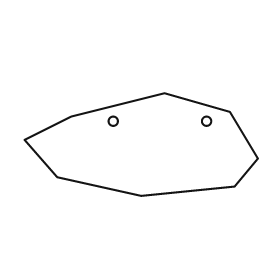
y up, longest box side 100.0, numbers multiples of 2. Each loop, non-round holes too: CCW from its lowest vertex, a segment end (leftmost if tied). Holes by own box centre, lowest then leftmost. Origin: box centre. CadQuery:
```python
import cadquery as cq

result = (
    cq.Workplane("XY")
    .moveTo(0.0, -22.0)
    .lineTo(40.0, -18.0)
    .lineTo(50.0, -6.0)
    .lineTo(38.0, 14.0)
    .lineTo(10.0, 22.0)
    .lineTo(-30.0, 12.0)
    .lineTo(-50.0, 2.0)
    .lineTo(-36.0, -14.0)
    .close()
    .moveTo(-12.0, 10.0)
    .circle(2.0)
    .moveTo(28.0, 10.0)
    .circle(2.0)
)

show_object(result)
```